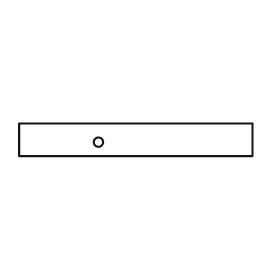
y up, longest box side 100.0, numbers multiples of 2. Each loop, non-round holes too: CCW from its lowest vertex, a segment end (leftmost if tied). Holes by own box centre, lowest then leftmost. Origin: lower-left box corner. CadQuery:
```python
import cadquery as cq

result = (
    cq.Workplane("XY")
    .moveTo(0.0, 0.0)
    .lineTo(100.0, 0.0)
    .lineTo(100.0, 14.0)
    .lineTo(0.0, 14.0)
    .close()
    .moveTo(34.0, 6.0)
    .circle(2.0)
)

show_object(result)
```